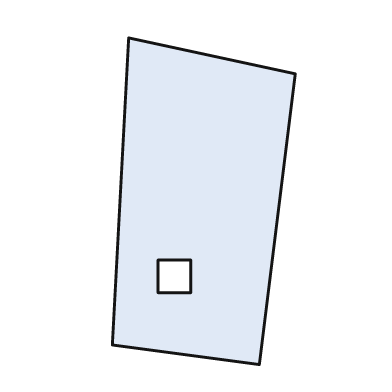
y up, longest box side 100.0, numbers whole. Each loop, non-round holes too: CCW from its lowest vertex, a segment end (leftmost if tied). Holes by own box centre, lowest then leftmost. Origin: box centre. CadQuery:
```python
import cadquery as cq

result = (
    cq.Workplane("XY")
    .moveTo(17.0, -50.0)
    .lineTo(28.0, 39.0)
    .lineTo(-23.0, 50.0)
    .lineTo(-28.0, -44.0)
    .close()
    .moveTo(-14.0, -28.0)
    .lineTo(-4.0, -28.0)
    .lineTo(-4.0, -18.0)
    .lineTo(-14.0, -18.0)
    .close()
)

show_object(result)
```